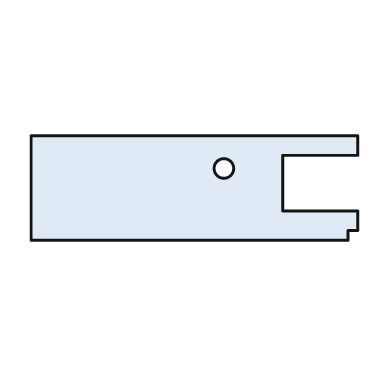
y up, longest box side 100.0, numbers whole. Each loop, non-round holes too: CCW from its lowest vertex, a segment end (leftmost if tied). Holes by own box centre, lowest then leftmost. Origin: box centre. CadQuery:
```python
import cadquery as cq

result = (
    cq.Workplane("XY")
    .moveTo(-50.0, -16.0)
    .lineTo(47.0, -16.0)
    .lineTo(47.0, -13.0)
    .lineTo(50.0, -13.0)
    .lineTo(50.0, -7.0)
    .lineTo(27.0, -7.0)
    .lineTo(27.0, 10.0)
    .lineTo(50.0, 10.0)
    .lineTo(50.0, 16.0)
    .lineTo(-50.0, 16.0)
    .close()
    .moveTo(9.0, 6.0)
    .circle(3.0)
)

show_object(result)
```